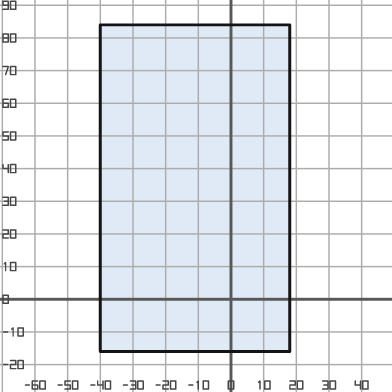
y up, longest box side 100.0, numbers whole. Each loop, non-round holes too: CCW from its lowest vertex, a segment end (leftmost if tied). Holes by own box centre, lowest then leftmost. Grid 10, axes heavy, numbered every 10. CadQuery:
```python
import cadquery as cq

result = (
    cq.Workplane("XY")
    .moveTo(-40.0, -16.0)
    .lineTo(18.0, -16.0)
    .lineTo(18.0, 84.0)
    .lineTo(-40.0, 84.0)
    .close()
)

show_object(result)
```